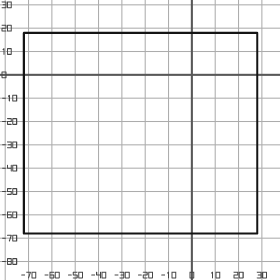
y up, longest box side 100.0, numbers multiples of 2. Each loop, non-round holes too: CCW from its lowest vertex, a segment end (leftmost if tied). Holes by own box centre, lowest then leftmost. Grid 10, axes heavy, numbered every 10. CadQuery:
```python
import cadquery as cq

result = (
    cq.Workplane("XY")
    .moveTo(-72.0, -68.0)
    .lineTo(28.0, -68.0)
    .lineTo(28.0, 18.0)
    .lineTo(-72.0, 18.0)
    .close()
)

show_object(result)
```